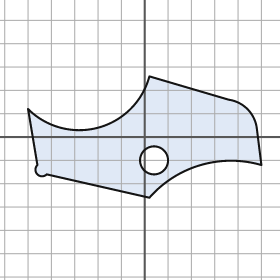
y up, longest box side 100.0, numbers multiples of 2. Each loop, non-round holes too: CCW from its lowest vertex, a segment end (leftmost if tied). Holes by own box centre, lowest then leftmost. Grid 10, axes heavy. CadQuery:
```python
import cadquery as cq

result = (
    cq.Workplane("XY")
    .moveTo(2.0, -26.0)
    .threePointArc((24.0, -12.0), (50.0, -12.0))
    .lineTo(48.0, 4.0)
    .threePointArc((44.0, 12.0), (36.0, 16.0))
    .lineTo(2.0, 26.0)
    .threePointArc((-20.0, 4.0), (-50.0, 12.0))
    .lineTo(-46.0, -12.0)
    .threePointArc((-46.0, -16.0), (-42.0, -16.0))
    .close()
    .moveTo(4.0, -10.0)
    .circle(6.0)
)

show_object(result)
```